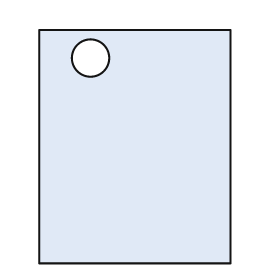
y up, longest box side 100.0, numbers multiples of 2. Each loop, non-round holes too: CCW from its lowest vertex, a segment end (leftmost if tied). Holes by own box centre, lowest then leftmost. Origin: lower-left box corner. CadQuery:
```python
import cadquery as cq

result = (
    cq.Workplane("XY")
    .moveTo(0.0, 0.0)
    .lineTo(82.0, 0.0)
    .lineTo(82.0, 100.0)
    .lineTo(0.0, 100.0)
    .close()
    .moveTo(22.0, 88.0)
    .circle(8.0)
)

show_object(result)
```